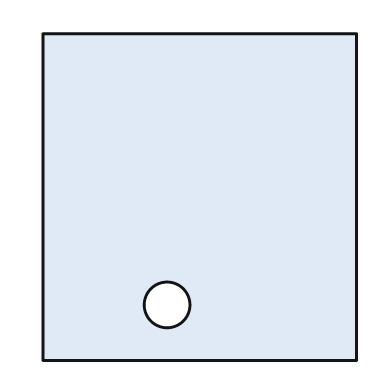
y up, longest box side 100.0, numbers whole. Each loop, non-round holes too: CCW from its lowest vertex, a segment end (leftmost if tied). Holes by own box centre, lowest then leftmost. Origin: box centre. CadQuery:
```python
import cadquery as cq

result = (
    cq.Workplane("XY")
    .moveTo(-48.0, -50.0)
    .lineTo(48.0, -50.0)
    .lineTo(48.0, 50.0)
    .lineTo(-48.0, 50.0)
    .close()
    .moveTo(-10.0, -33.0)
    .circle(7.0)
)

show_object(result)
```